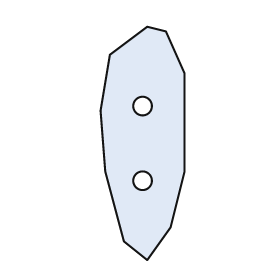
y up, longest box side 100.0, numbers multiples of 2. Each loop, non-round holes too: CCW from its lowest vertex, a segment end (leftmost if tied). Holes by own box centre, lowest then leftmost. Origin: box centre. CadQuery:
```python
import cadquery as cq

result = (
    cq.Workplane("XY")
    .moveTo(2.0, -50.0)
    .lineTo(12.0, -36.0)
    .lineTo(18.0, -12.0)
    .lineTo(18.0, 30.0)
    .lineTo(10.0, 48.0)
    .lineTo(2.0, 50.0)
    .lineTo(-14.0, 38.0)
    .lineTo(-18.0, 14.0)
    .lineTo(-16.0, -12.0)
    .lineTo(-8.0, -42.0)
    .close()
    .moveTo(0.0, -16.0)
    .circle(4.0)
    .moveTo(0.0, 16.0)
    .circle(4.0)
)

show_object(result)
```